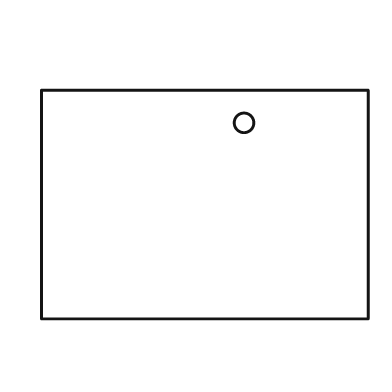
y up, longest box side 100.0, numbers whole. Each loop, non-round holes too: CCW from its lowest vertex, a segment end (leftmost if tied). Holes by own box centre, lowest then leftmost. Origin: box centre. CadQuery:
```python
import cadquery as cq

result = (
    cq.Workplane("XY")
    .moveTo(-50.0, -35.0)
    .lineTo(50.0, -35.0)
    .lineTo(50.0, 35.0)
    .lineTo(-50.0, 35.0)
    .close()
    .moveTo(12.0, 25.0)
    .circle(3.0)
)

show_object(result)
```